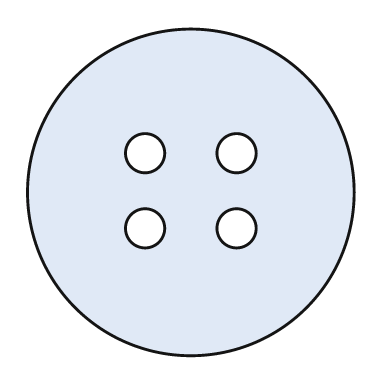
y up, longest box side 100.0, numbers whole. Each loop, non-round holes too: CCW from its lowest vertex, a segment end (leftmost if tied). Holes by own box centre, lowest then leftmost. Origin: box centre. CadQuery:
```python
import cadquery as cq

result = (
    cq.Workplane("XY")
    .moveTo(0.0, 0.0)
    .circle(50.0)
    .moveTo(-14.0, -11.0)
    .circle(6.0)
    .moveTo(14.0, -11.0)
    .circle(6.0)
    .moveTo(-14.0, 12.0)
    .circle(6.0)
    .moveTo(14.0, 12.0)
    .circle(6.0)
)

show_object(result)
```